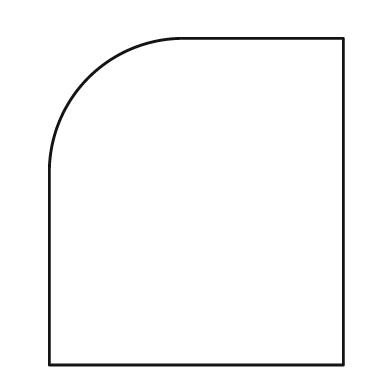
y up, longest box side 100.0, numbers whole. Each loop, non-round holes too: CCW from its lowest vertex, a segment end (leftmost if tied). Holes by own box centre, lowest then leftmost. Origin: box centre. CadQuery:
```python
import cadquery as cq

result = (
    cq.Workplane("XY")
    .moveTo(-45.0, -50.0)
    .lineTo(45.0, -50.0)
    .lineTo(45.0, 50.0)
    .lineTo(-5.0, 50.0)
    .threePointArc((-33.0, 38.0), (-45.0, 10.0))
    .close()
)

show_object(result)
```